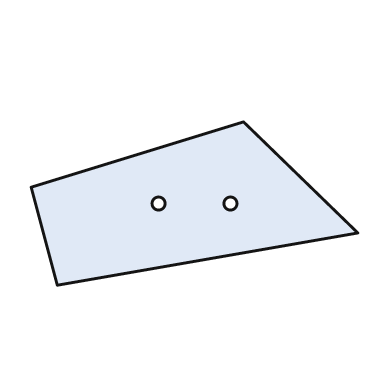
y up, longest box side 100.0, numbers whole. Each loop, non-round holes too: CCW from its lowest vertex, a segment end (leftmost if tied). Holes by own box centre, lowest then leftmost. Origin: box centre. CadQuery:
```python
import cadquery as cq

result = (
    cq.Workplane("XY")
    .moveTo(-42.0, -25.0)
    .lineTo(50.0, -9.0)
    .lineTo(15.0, 25.0)
    .lineTo(-50.0, 5.0)
    .close()
    .moveTo(-11.0, 0.0)
    .circle(2.0)
    .moveTo(11.0, 0.0)
    .circle(2.0)
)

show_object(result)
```